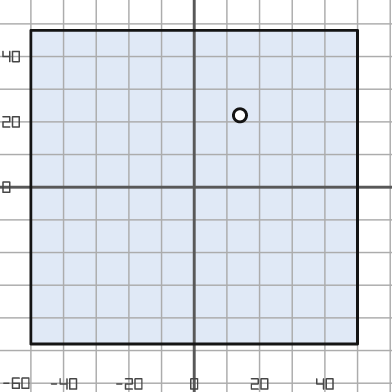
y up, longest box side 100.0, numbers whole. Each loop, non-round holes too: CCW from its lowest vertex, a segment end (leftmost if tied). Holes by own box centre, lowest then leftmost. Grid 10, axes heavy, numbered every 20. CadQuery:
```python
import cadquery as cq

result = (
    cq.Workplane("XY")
    .moveTo(-50.0, -48.0)
    .lineTo(50.0, -48.0)
    .lineTo(50.0, 48.0)
    .lineTo(-50.0, 48.0)
    .close()
    .moveTo(14.0, 22.0)
    .circle(2.0)
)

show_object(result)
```